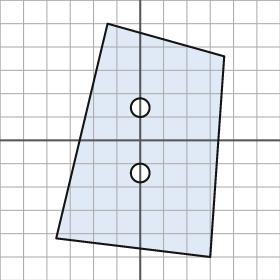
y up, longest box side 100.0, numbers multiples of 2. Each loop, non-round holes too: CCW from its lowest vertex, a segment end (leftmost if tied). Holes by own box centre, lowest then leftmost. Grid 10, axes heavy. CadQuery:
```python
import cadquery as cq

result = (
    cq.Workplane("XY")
    .moveTo(30.0, -50.0)
    .lineTo(36.0, 36.0)
    .lineTo(-14.0, 50.0)
    .lineTo(-36.0, -42.0)
    .close()
    .moveTo(0.0, -14.0)
    .circle(4.0)
    .moveTo(0.0, 14.0)
    .circle(4.0)
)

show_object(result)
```